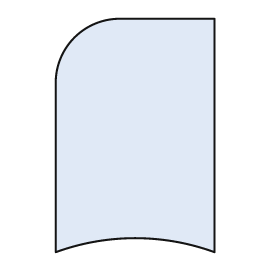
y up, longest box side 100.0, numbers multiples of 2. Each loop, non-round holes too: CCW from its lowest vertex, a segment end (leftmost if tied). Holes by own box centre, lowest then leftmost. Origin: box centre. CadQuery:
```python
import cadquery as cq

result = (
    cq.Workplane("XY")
    .moveTo(-34.0, -50.0)
    .threePointArc((0.0, -44.0), (34.0, -50.0))
    .lineTo(34.0, 50.0)
    .lineTo(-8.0, 50.0)
    .threePointArc((-26.0, 42.0), (-34.0, 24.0))
    .close()
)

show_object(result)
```